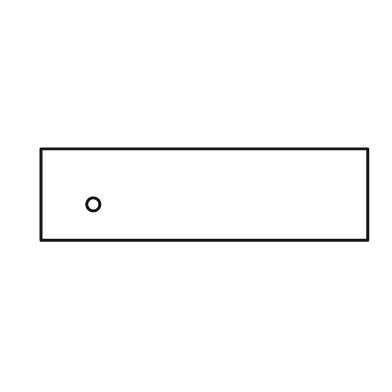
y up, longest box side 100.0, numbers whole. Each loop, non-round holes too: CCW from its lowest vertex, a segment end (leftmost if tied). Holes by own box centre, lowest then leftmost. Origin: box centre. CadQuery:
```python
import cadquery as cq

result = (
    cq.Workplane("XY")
    .moveTo(-50.0, -14.0)
    .lineTo(50.0, -14.0)
    .lineTo(50.0, 14.0)
    .lineTo(-50.0, 14.0)
    .close()
    .moveTo(-34.0, -3.0)
    .circle(2.0)
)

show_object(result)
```